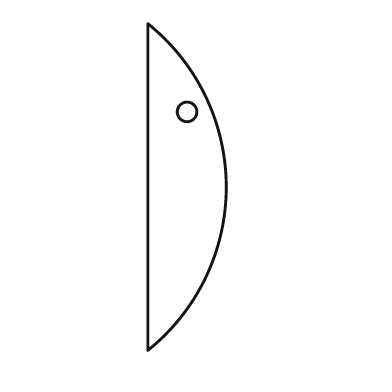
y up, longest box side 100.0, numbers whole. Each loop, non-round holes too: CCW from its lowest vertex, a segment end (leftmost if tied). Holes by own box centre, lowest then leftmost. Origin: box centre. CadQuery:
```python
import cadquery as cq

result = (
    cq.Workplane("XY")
    .moveTo(-12.0, -50.0)
    .threePointArc((12.0, 0.0), (-12.0, 50.0))
    .close()
    .moveTo(0.0, 23.0)
    .circle(3.0)
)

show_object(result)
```